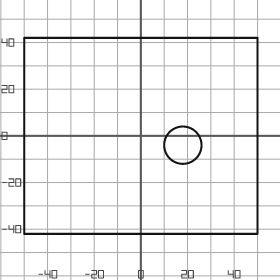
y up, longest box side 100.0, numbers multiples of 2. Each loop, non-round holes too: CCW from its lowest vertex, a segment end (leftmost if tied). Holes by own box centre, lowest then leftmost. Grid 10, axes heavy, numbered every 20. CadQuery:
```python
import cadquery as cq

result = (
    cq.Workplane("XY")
    .moveTo(-50.0, -42.0)
    .lineTo(50.0, -42.0)
    .lineTo(50.0, 42.0)
    .lineTo(-50.0, 42.0)
    .close()
    .moveTo(18.0, -4.0)
    .circle(8.0)
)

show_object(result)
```